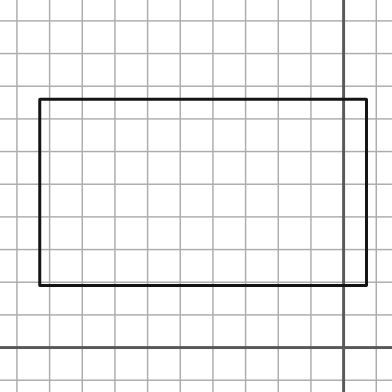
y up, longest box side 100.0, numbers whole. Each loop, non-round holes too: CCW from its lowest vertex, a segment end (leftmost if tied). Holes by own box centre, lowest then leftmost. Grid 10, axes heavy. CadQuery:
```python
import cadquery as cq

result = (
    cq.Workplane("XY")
    .moveTo(-93.0, 19.0)
    .lineTo(7.0, 19.0)
    .lineTo(7.0, 76.0)
    .lineTo(-93.0, 76.0)
    .close()
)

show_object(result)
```